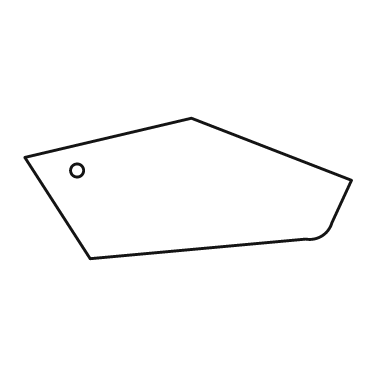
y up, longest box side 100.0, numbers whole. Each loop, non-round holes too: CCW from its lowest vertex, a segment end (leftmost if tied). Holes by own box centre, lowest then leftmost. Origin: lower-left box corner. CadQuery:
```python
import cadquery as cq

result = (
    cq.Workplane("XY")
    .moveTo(20.0, 0.0)
    .lineTo(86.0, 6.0)
    .threePointArc((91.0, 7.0), (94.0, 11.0))
    .lineTo(100.0, 24.0)
    .lineTo(51.0, 43.0)
    .lineTo(0.0, 31.0)
    .close()
    .moveTo(16.0, 27.0)
    .circle(2.0)
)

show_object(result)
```